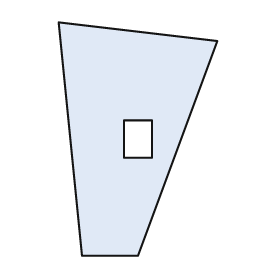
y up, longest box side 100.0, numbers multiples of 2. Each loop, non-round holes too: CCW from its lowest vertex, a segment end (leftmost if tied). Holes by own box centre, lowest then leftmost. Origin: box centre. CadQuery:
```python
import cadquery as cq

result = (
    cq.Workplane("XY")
    .moveTo(-24.0, -50.0)
    .lineTo(0.0, -50.0)
    .lineTo(34.0, 42.0)
    .lineTo(-34.0, 50.0)
    .close()
    .moveTo(-6.0, -8.0)
    .lineTo(6.0, -8.0)
    .lineTo(6.0, 8.0)
    .lineTo(-6.0, 8.0)
    .close()
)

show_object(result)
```